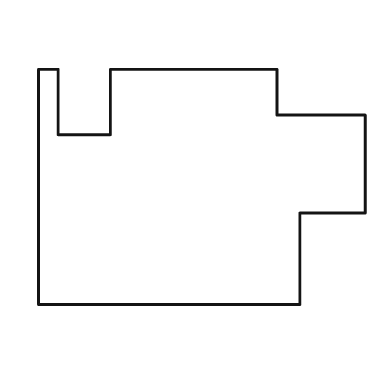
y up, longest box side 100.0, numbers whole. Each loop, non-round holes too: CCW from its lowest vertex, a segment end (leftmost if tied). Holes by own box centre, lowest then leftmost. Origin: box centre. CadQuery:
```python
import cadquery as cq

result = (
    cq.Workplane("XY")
    .moveTo(-50.0, -36.0)
    .lineTo(30.0, -36.0)
    .lineTo(30.0, -8.0)
    .lineTo(50.0, -8.0)
    .lineTo(50.0, 22.0)
    .lineTo(23.0, 22.0)
    .lineTo(23.0, 36.0)
    .lineTo(-28.0, 36.0)
    .lineTo(-28.0, 16.0)
    .lineTo(-44.0, 16.0)
    .lineTo(-44.0, 36.0)
    .lineTo(-50.0, 36.0)
    .close()
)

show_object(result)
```